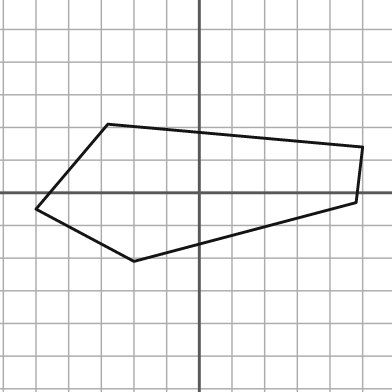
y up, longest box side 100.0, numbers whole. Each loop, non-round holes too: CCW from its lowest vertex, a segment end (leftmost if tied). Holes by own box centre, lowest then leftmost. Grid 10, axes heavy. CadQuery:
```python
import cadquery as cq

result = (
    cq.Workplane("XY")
    .moveTo(-20.0, -21.0)
    .lineTo(48.0, -3.0)
    .lineTo(50.0, 14.0)
    .lineTo(-28.0, 21.0)
    .lineTo(-50.0, -5.0)
    .close()
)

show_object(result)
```